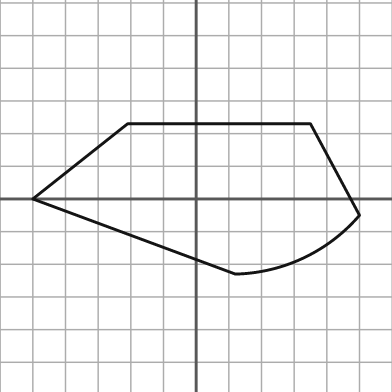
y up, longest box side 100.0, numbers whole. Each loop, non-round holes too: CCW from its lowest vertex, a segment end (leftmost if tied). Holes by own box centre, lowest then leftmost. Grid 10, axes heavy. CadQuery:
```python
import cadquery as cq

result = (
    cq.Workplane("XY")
    .moveTo(12.0, -23.0)
    .threePointArc((33.0, -18.0), (50.0, -5.0))
    .lineTo(35.0, 23.0)
    .lineTo(-21.0, 23.0)
    .lineTo(-50.0, 0.0)
    .close()
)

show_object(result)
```